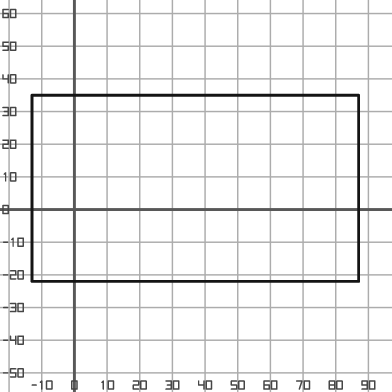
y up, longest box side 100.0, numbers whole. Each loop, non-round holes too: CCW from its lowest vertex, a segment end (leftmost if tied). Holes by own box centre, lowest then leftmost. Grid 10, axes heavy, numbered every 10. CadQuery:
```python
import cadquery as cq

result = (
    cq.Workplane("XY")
    .moveTo(-13.0, -22.0)
    .lineTo(87.0, -22.0)
    .lineTo(87.0, 35.0)
    .lineTo(-13.0, 35.0)
    .close()
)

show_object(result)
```